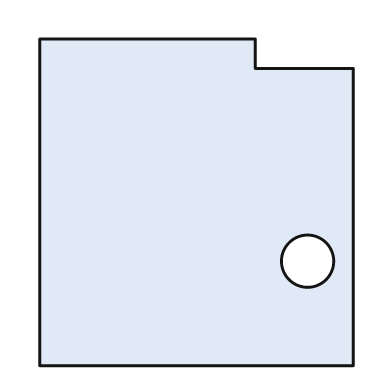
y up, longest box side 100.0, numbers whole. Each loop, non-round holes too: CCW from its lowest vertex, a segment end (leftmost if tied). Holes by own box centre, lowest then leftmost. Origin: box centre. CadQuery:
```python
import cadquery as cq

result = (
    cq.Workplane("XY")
    .moveTo(-48.0, -50.0)
    .lineTo(48.0, -50.0)
    .lineTo(48.0, 41.0)
    .lineTo(18.0, 41.0)
    .lineTo(18.0, 50.0)
    .lineTo(-48.0, 50.0)
    .close()
    .moveTo(34.0, -18.0)
    .circle(8.0)
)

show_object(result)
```